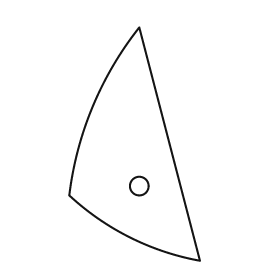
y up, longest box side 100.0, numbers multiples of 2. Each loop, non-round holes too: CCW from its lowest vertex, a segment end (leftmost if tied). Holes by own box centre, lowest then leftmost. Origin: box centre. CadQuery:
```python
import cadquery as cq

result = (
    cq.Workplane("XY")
    .moveTo(28.0, -50.0)
    .lineTo(2.0, 50.0)
    .threePointArc((-18.0, 16.0), (-28.0, -22.0))
    .threePointArc((-2.0, -40.0), (28.0, -50.0))
    .close()
    .moveTo(2.0, -18.0)
    .circle(4.0)
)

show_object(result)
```